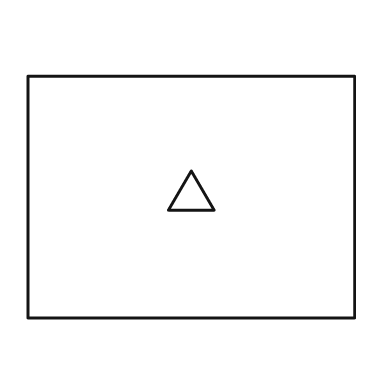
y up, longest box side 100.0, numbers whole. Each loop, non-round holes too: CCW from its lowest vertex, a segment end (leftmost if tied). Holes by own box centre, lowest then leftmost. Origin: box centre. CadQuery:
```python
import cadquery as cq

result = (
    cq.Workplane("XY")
    .moveTo(-50.0, -37.0)
    .lineTo(50.0, -37.0)
    .lineTo(50.0, 37.0)
    .lineTo(-50.0, 37.0)
    .close()
    .moveTo(-7.0, -4.0)
    .lineTo(7.0, -4.0)
    .lineTo(0.0, 8.0)
    .close()
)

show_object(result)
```